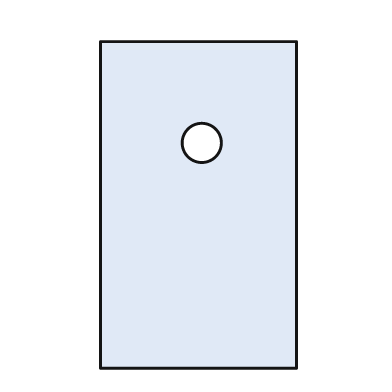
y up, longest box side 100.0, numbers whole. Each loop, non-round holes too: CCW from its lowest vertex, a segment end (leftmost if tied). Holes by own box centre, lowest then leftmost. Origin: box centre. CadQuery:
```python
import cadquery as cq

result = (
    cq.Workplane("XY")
    .moveTo(-30.0, -50.0)
    .lineTo(30.0, -50.0)
    .lineTo(30.0, 50.0)
    .lineTo(-30.0, 50.0)
    .close()
    .moveTo(1.0, 19.0)
    .circle(6.0)
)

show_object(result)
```